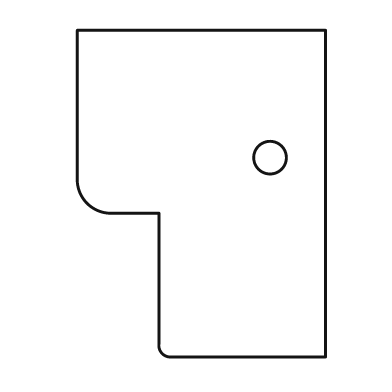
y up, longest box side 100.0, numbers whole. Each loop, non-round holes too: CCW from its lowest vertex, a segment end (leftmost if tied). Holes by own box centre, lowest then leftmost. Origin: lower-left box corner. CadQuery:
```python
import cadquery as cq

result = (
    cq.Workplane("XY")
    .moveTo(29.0, 0.0)
    .lineTo(76.0, 0.0)
    .lineTo(76.0, 100.0)
    .lineTo(0.0, 100.0)
    .lineTo(0.0, 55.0)
    .threePointArc((3.0, 47.0), (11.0, 44.0))
    .lineTo(25.0, 44.0)
    .lineTo(25.0, 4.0)
    .threePointArc((26.0, 1.0), (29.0, 0.0))
    .close()
    .moveTo(59.0, 61.0)
    .circle(5.0)
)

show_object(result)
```